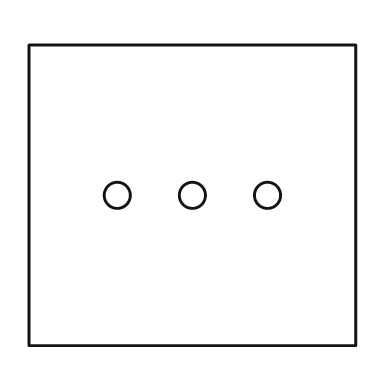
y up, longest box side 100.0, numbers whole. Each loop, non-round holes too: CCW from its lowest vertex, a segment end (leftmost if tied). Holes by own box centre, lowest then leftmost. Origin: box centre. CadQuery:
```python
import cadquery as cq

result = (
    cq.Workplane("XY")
    .moveTo(-50.0, -46.0)
    .lineTo(50.0, -46.0)
    .lineTo(50.0, 46.0)
    .lineTo(-50.0, 46.0)
    .close()
    .moveTo(-23.0, 0.0)
    .circle(4.0)
    .moveTo(0.0, 0.0)
    .circle(4.0)
    .moveTo(23.0, 0.0)
    .circle(4.0)
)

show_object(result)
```